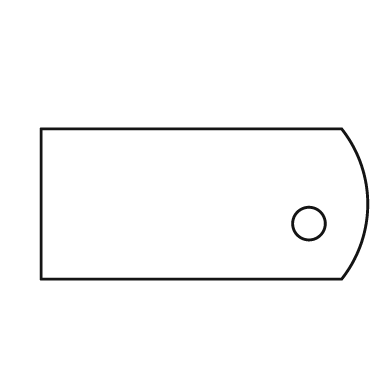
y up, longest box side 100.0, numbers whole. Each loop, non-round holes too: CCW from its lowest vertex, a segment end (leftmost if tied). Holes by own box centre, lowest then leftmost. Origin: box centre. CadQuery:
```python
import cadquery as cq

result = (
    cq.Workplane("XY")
    .moveTo(-50.0, -23.0)
    .lineTo(42.0, -23.0)
    .threePointArc((50.0, 0.0), (42.0, 23.0))
    .lineTo(-50.0, 23.0)
    .close()
    .moveTo(32.0, -6.0)
    .circle(5.0)
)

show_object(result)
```